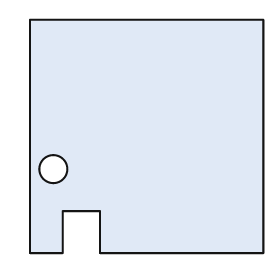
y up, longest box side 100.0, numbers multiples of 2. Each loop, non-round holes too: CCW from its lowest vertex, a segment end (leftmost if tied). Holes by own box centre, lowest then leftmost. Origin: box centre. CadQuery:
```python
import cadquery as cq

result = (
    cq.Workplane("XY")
    .moveTo(-50.0, -50.0)
    .lineTo(-36.0, -50.0)
    .lineTo(-36.0, -32.0)
    .lineTo(-20.0, -32.0)
    .lineTo(-20.0, -50.0)
    .lineTo(50.0, -50.0)
    .lineTo(50.0, 50.0)
    .lineTo(-50.0, 50.0)
    .close()
    .moveTo(-40.0, -14.0)
    .circle(6.0)
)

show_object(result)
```